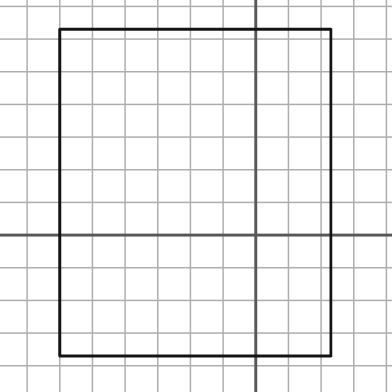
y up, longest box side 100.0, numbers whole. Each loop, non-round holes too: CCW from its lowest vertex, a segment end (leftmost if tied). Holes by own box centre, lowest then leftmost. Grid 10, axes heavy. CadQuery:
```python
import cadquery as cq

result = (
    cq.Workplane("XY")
    .moveTo(-60.0, -37.0)
    .lineTo(23.0, -37.0)
    .lineTo(23.0, 63.0)
    .lineTo(-60.0, 63.0)
    .close()
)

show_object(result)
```